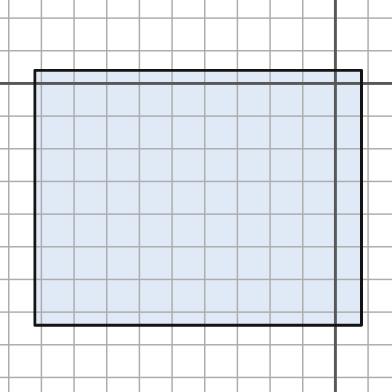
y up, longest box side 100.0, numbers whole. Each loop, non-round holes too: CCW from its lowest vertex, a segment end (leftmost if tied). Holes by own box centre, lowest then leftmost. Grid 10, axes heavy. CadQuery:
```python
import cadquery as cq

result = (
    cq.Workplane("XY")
    .moveTo(-92.0, -74.0)
    .lineTo(8.0, -74.0)
    .lineTo(8.0, 4.0)
    .lineTo(-92.0, 4.0)
    .close()
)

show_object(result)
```